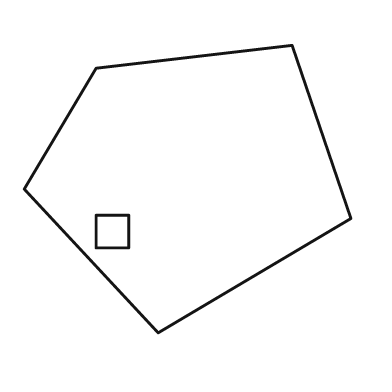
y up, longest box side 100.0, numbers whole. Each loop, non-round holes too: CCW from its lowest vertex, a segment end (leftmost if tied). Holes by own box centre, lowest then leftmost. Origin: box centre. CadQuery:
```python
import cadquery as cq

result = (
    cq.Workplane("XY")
    .moveTo(-9.0, -44.0)
    .lineTo(50.0, -9.0)
    .lineTo(32.0, 44.0)
    .lineTo(-28.0, 37.0)
    .lineTo(-50.0, 0.0)
    .close()
    .moveTo(-28.0, -18.0)
    .lineTo(-18.0, -18.0)
    .lineTo(-18.0, -8.0)
    .lineTo(-28.0, -8.0)
    .close()
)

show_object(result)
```